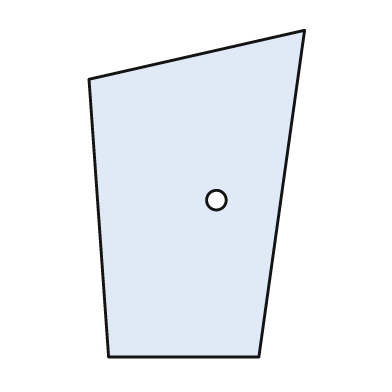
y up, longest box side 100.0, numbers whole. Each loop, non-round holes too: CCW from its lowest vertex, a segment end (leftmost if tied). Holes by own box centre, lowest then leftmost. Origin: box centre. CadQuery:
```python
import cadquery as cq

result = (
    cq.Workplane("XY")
    .moveTo(-27.0, -50.0)
    .lineTo(19.0, -50.0)
    .lineTo(33.0, 50.0)
    .lineTo(-33.0, 35.0)
    .close()
    .moveTo(6.0, -2.0)
    .circle(3.0)
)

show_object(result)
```